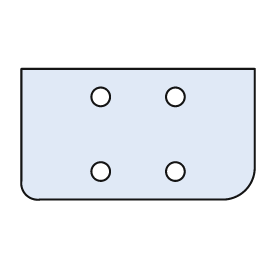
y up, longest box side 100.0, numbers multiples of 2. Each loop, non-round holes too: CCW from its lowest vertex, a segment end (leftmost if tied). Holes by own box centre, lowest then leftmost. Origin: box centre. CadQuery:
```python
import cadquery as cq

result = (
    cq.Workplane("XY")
    .moveTo(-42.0, -28.0)
    .lineTo(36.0, -28.0)
    .threePointArc((46.0, -24.0), (50.0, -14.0))
    .lineTo(50.0, 28.0)
    .lineTo(-50.0, 28.0)
    .lineTo(-50.0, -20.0)
    .threePointArc((-48.0, -26.0), (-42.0, -28.0))
    .close()
    .moveTo(-16.0, -16.0)
    .circle(4.0)
    .moveTo(16.0, -16.0)
    .circle(4.0)
    .moveTo(-16.0, 16.0)
    .circle(4.0)
    .moveTo(16.0, 16.0)
    .circle(4.0)
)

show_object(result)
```